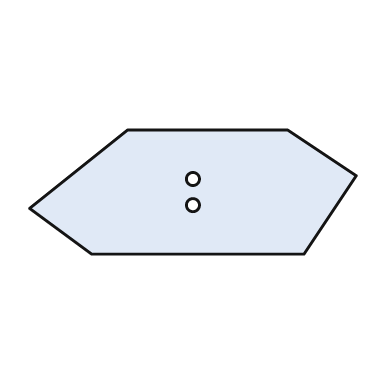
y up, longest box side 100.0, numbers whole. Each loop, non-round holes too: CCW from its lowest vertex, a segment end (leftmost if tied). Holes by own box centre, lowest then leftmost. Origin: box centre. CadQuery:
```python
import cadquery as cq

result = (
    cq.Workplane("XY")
    .moveTo(-31.0, -19.0)
    .lineTo(34.0, -19.0)
    .lineTo(50.0, 5.0)
    .lineTo(29.0, 19.0)
    .lineTo(-20.0, 19.0)
    .lineTo(-50.0, -5.0)
    .close()
    .moveTo(0.0, -4.0)
    .circle(2.0)
    .moveTo(0.0, 4.0)
    .circle(2.0)
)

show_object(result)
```